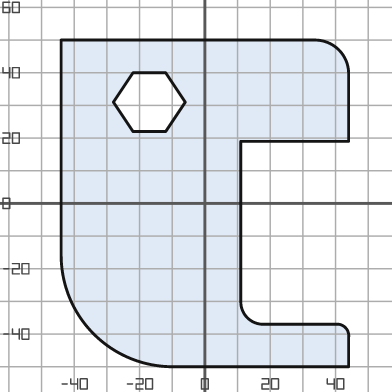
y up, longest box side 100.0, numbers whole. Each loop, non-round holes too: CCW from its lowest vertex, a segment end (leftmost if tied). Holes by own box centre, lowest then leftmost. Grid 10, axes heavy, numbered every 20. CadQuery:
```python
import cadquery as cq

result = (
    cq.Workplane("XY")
    .moveTo(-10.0, -50.0)
    .lineTo(44.0, -50.0)
    .lineTo(44.0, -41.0)
    .threePointArc((43.0, -38.0), (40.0, -37.0))
    .lineTo(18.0, -37.0)
    .threePointArc((13.0, -35.0), (11.0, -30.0))
    .lineTo(11.0, 19.0)
    .lineTo(44.0, 19.0)
    .lineTo(44.0, 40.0)
    .threePointArc((41.0, 47.0), (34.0, 50.0))
    .lineTo(-44.0, 50.0)
    .lineTo(-44.0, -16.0)
    .threePointArc((-34.0, -40.0), (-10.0, -50.0))
    .close()
    .moveTo(-22.0, 22.0)
    .lineTo(-12.0, 22.0)
    .lineTo(-6.0, 31.0)
    .lineTo(-12.0, 40.0)
    .lineTo(-22.0, 40.0)
    .lineTo(-28.0, 31.0)
    .close()
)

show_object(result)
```